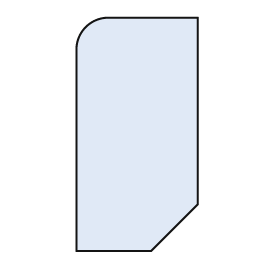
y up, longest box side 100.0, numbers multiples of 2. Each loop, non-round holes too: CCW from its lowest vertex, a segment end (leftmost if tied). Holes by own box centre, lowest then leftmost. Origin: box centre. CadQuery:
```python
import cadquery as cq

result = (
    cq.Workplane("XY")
    .moveTo(-26.0, -50.0)
    .lineTo(6.0, -50.0)
    .lineTo(26.0, -30.0)
    .lineTo(26.0, 50.0)
    .lineTo(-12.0, 50.0)
    .threePointArc((-22.0, 46.0), (-26.0, 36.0))
    .close()
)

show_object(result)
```